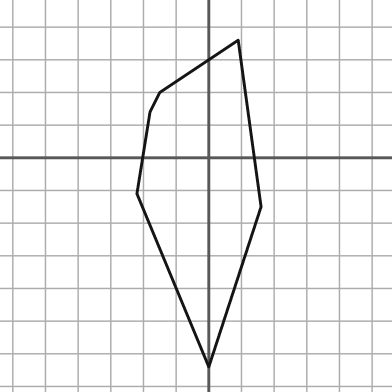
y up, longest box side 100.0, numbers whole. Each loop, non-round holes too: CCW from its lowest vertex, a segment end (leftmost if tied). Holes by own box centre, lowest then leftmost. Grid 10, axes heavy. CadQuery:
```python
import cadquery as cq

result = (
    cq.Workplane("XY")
    .moveTo(0.0, -64.0)
    .lineTo(16.0, -15.0)
    .lineTo(9.0, 36.0)
    .lineTo(-15.0, 20.0)
    .lineTo(-18.0, 14.0)
    .lineTo(-22.0, -11.0)
    .close()
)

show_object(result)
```